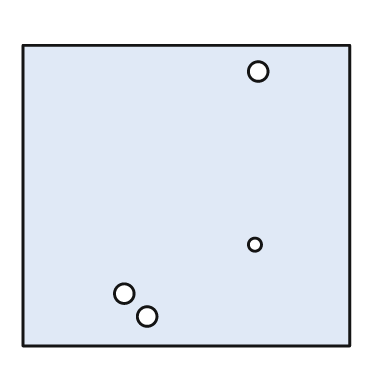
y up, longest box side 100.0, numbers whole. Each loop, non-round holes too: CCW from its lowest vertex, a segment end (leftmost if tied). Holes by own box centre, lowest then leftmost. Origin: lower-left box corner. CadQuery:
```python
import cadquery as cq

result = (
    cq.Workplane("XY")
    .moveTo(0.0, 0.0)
    .lineTo(100.0, 0.0)
    .lineTo(100.0, 92.0)
    .lineTo(0.0, 92.0)
    .close()
    .moveTo(38.0, 9.0)
    .circle(3.0)
    .moveTo(31.0, 16.0)
    .circle(3.0)
    .moveTo(71.0, 31.0)
    .circle(2.0)
    .moveTo(72.0, 84.0)
    .circle(3.0)
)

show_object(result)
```